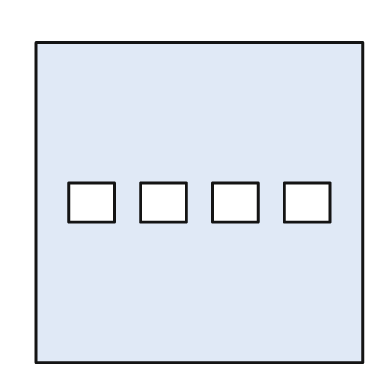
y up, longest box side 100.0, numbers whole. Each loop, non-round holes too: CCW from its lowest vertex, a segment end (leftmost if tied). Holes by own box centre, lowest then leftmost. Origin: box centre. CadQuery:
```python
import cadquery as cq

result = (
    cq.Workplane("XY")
    .moveTo(-50.0, -49.0)
    .lineTo(50.0, -49.0)
    .lineTo(50.0, 49.0)
    .lineTo(-50.0, 49.0)
    .close()
    .moveTo(-40.0, -6.0)
    .lineTo(-26.0, -6.0)
    .lineTo(-26.0, 6.0)
    .lineTo(-40.0, 6.0)
    .close()
    .moveTo(-18.0, -6.0)
    .lineTo(-4.0, -6.0)
    .lineTo(-4.0, 6.0)
    .lineTo(-18.0, 6.0)
    .close()
    .moveTo(4.0, -6.0)
    .lineTo(18.0, -6.0)
    .lineTo(18.0, 6.0)
    .lineTo(4.0, 6.0)
    .close()
    .moveTo(26.0, -6.0)
    .lineTo(40.0, -6.0)
    .lineTo(40.0, 6.0)
    .lineTo(26.0, 6.0)
    .close()
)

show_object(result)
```